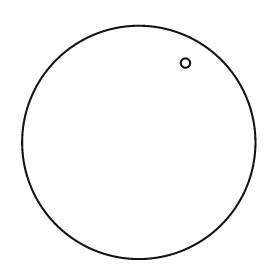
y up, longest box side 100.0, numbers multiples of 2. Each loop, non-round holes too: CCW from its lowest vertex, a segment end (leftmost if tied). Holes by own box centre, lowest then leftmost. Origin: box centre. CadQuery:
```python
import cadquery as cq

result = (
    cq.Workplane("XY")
    .moveTo(0.0, 0.0)
    .circle(50.0)
    .moveTo(20.0, 34.0)
    .circle(2.0)
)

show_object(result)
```